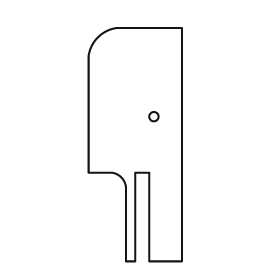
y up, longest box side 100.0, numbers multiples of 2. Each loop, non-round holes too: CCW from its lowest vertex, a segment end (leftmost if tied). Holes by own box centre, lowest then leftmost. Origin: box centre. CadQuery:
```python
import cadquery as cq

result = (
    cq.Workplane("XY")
    .moveTo(-4.0, -50.0)
    .lineTo(0.0, -50.0)
    .lineTo(0.0, -12.0)
    .lineTo(6.0, -12.0)
    .lineTo(6.0, -50.0)
    .lineTo(20.0, -50.0)
    .lineTo(20.0, 50.0)
    .lineTo(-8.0, 50.0)
    .threePointArc((-16.0, 46.0), (-20.0, 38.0))
    .lineTo(-20.0, -12.0)
    .lineTo(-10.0, -12.0)
    .threePointArc((-6.0, -14.0), (-4.0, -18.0))
    .close()
    .moveTo(8.0, 12.0)
    .circle(2.0)
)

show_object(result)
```